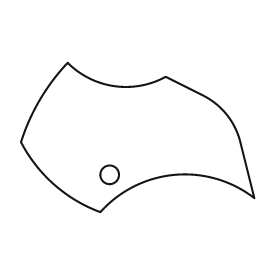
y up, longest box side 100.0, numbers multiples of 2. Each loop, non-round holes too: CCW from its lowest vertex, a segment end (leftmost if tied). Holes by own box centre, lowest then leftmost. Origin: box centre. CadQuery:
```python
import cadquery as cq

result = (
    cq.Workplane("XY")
    .moveTo(-16.0, -32.0)
    .threePointArc((16.0, -16.0), (50.0, -26.0))
    .lineTo(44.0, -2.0)
    .threePointArc((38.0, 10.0), (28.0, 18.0))
    .lineTo(12.0, 26.0)
    .threePointArc((-10.0, 22.0), (-30.0, 32.0))
    .threePointArc((-42.0, 16.0), (-50.0, -2.0))
    .threePointArc((-36.0, -20.0), (-16.0, -32.0))
    .close()
    .moveTo(-12.0, -16.0)
    .circle(4.0)
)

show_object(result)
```